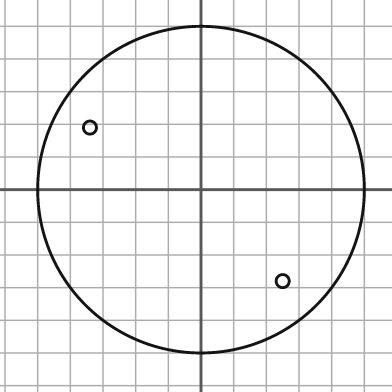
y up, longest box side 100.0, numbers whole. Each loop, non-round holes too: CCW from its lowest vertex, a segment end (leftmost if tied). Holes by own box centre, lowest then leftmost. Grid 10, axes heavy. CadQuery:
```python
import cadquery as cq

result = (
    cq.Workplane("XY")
    .moveTo(0.0, 0.0)
    .circle(50.0)
    .moveTo(25.0, -28.0)
    .circle(2.0)
    .moveTo(-34.0, 19.0)
    .circle(2.0)
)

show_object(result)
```